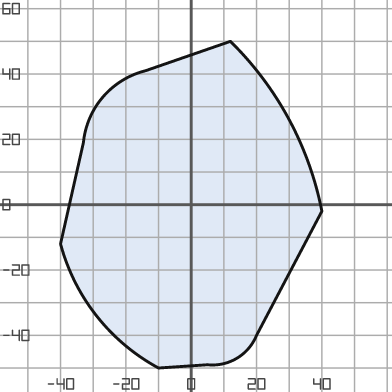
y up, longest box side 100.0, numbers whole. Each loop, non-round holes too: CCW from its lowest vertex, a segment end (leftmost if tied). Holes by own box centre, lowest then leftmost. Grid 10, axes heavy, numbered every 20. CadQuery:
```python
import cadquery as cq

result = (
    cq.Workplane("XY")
    .moveTo(-10.0, -50.0)
    .lineTo(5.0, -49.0)
    .threePointArc((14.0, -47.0), (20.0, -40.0))
    .lineTo(40.0, -2.0)
    .threePointArc((30.0, 26.0), (12.0, 50.0))
    .lineTo(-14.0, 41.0)
    .threePointArc((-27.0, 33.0), (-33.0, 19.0))
    .lineTo(-40.0, -12.0)
    .threePointArc((-29.0, -34.0), (-10.0, -50.0))
    .close()
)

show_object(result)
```